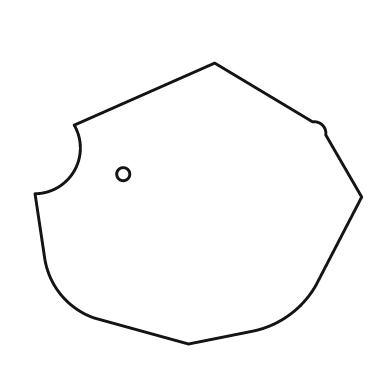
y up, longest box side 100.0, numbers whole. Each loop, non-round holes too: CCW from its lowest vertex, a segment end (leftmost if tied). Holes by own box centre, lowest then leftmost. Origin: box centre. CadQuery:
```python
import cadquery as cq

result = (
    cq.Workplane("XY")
    .moveTo(-3.0, -43.0)
    .lineTo(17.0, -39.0)
    .threePointArc((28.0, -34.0), (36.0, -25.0))
    .lineTo(50.0, 2.0)
    .lineTo(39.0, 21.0)
    .threePointArc((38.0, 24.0), (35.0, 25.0))
    .lineTo(5.0, 43.0)
    .lineTo(-38.0, 24.0)
    .threePointArc((-38.0, 10.0), (-50.0, 3.0))
    .lineTo(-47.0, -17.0)
    .threePointArc((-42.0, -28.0), (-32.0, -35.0))
    .close()
    .moveTo(-23.0, 9.0)
    .circle(2.0)
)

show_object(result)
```